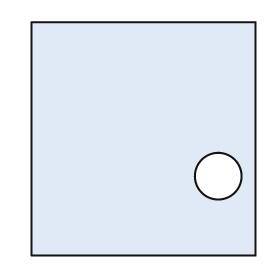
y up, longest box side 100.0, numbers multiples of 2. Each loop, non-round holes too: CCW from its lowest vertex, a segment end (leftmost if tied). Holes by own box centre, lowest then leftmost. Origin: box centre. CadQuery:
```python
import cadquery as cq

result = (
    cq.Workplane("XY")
    .moveTo(-48.0, -50.0)
    .lineTo(48.0, -50.0)
    .lineTo(48.0, 50.0)
    .lineTo(-48.0, 50.0)
    .close()
    .moveTo(32.0, -16.0)
    .circle(10.0)
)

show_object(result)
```